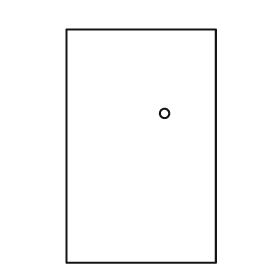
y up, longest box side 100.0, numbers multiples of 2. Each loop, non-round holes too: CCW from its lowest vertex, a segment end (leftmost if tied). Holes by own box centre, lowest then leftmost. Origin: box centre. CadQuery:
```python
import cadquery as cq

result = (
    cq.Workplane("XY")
    .moveTo(-32.0, -50.0)
    .lineTo(32.0, -50.0)
    .lineTo(32.0, 50.0)
    .lineTo(-32.0, 50.0)
    .close()
    .moveTo(10.0, 14.0)
    .circle(2.0)
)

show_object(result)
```